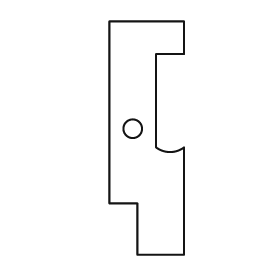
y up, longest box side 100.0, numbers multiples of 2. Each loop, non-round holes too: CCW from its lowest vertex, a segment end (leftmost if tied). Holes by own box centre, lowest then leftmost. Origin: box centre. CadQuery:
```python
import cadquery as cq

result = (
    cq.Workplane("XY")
    .moveTo(-4.0, -50.0)
    .lineTo(16.0, -50.0)
    .lineTo(16.0, -4.0)
    .threePointArc((10.0, -6.0), (4.0, -4.0))
    .lineTo(4.0, 36.0)
    .lineTo(16.0, 36.0)
    .lineTo(16.0, 50.0)
    .lineTo(-16.0, 50.0)
    .lineTo(-16.0, -28.0)
    .lineTo(-4.0, -28.0)
    .close()
    .moveTo(-6.0, 4.0)
    .circle(4.0)
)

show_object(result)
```